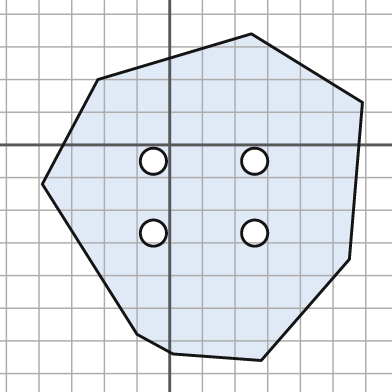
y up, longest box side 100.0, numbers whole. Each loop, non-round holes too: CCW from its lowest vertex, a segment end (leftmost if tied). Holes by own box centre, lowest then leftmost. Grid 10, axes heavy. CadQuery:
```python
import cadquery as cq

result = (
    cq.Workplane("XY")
    .moveTo(28.0, -66.0)
    .lineTo(55.0, -35.0)
    .lineTo(59.0, 13.0)
    .lineTo(25.0, 34.0)
    .lineTo(-22.0, 20.0)
    .lineTo(-39.0, -12.0)
    .lineTo(-10.0, -58.0)
    .lineTo(1.0, -64.0)
    .close()
    .moveTo(-5.0, -27.0)
    .circle(4.0)
    .moveTo(26.0, -27.0)
    .circle(4.0)
    .moveTo(-5.0, -5.0)
    .circle(4.0)
    .moveTo(26.0, -5.0)
    .circle(4.0)
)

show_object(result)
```